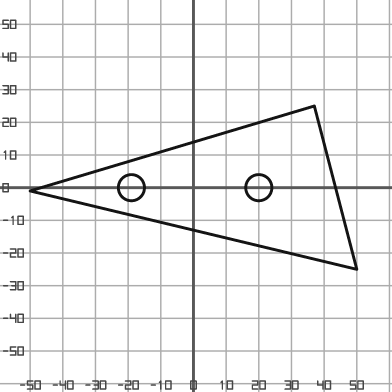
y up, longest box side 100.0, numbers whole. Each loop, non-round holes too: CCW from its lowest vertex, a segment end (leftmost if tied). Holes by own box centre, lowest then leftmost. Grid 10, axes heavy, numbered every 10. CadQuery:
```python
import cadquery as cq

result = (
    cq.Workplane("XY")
    .moveTo(50.0, -25.0)
    .lineTo(37.0, 25.0)
    .lineTo(-50.0, -1.0)
    .close()
    .moveTo(-19.0, 0.0)
    .circle(4.0)
    .moveTo(20.0, 0.0)
    .circle(4.0)
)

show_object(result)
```